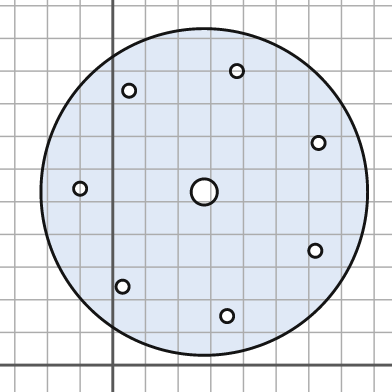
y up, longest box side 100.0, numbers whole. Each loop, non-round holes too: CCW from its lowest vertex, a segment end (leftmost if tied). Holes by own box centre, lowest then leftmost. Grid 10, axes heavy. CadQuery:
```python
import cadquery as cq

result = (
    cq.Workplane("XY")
    .moveTo(28.0, 53.0)
    .circle(50.0)
    .moveTo(35.0, 15.0)
    .circle(2.0)
    .moveTo(3.0, 24.0)
    .circle(2.0)
    .moveTo(62.0, 35.0)
    .circle(2.0)
    .moveTo(28.0, 53.0)
    .circle(4.0)
    .moveTo(-10.0, 54.0)
    .circle(2.0)
    .moveTo(63.0, 68.0)
    .circle(2.0)
    .moveTo(5.0, 84.0)
    .circle(2.0)
    .moveTo(38.0, 90.0)
    .circle(2.0)
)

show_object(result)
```